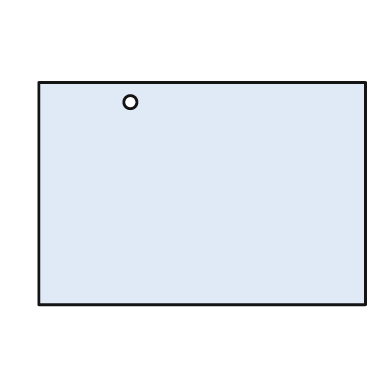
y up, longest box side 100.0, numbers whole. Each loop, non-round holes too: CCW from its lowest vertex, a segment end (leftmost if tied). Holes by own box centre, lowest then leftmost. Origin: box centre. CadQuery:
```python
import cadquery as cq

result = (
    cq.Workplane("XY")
    .moveTo(-50.0, -34.0)
    .lineTo(50.0, -34.0)
    .lineTo(50.0, 34.0)
    .lineTo(-50.0, 34.0)
    .close()
    .moveTo(-22.0, 28.0)
    .circle(2.0)
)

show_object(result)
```